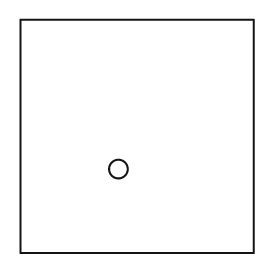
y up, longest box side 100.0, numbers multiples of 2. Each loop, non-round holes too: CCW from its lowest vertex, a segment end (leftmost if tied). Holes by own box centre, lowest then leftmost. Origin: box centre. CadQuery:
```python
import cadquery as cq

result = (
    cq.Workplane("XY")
    .moveTo(-50.0, -50.0)
    .lineTo(50.0, -50.0)
    .lineTo(50.0, 50.0)
    .lineTo(-50.0, 50.0)
    .close()
    .moveTo(-8.0, -14.0)
    .circle(4.0)
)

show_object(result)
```